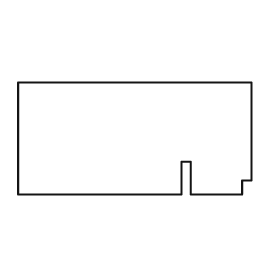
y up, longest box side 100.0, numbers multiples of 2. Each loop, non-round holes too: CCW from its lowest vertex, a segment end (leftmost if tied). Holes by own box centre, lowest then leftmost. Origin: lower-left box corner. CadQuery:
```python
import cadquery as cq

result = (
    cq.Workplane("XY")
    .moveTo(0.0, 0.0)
    .lineTo(70.0, 0.0)
    .lineTo(70.0, 14.0)
    .lineTo(74.0, 14.0)
    .lineTo(74.0, 0.0)
    .lineTo(96.0, 0.0)
    .lineTo(96.0, 6.0)
    .lineTo(100.0, 6.0)
    .lineTo(100.0, 48.0)
    .lineTo(0.0, 48.0)
    .close()
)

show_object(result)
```